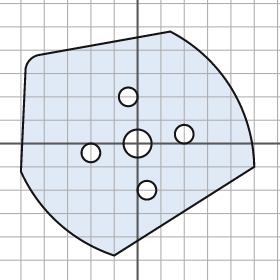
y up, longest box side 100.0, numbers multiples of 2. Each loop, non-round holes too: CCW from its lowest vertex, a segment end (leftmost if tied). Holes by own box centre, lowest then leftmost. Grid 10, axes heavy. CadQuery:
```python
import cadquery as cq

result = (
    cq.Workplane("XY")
    .moveTo(-10.0, -48.0)
    .lineTo(50.0, -10.0)
    .threePointArc((40.0, 24.0), (14.0, 48.0))
    .lineTo(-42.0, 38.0)
    .threePointArc((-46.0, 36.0), (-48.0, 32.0))
    .lineTo(-50.0, -12.0)
    .threePointArc((-34.0, -34.0), (-10.0, -48.0))
    .close()
    .moveTo(4.0, -20.0)
    .circle(4.0)
    .moveTo(-20.0, -4.0)
    .circle(4.0)
    .moveTo(0.0, 0.0)
    .circle(6.0)
    .moveTo(20.0, 4.0)
    .circle(4.0)
    .moveTo(-4.0, 20.0)
    .circle(4.0)
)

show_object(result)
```